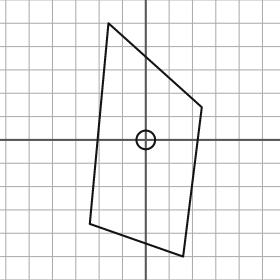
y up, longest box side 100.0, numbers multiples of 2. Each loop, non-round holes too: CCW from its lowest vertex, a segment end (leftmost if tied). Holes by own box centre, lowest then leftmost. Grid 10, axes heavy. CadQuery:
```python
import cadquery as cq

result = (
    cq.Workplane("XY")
    .moveTo(16.0, -50.0)
    .lineTo(24.0, 14.0)
    .lineTo(-16.0, 50.0)
    .lineTo(-24.0, -36.0)
    .close()
    .moveTo(0.0, 0.0)
    .circle(4.0)
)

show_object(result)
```